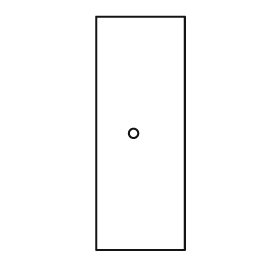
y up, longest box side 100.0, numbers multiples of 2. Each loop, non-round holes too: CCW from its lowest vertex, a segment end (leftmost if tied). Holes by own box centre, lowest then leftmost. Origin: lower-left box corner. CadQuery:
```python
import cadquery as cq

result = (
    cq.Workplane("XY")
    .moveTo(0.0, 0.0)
    .lineTo(38.0, 0.0)
    .lineTo(38.0, 100.0)
    .lineTo(0.0, 100.0)
    .close()
    .moveTo(16.0, 50.0)
    .circle(2.0)
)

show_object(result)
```